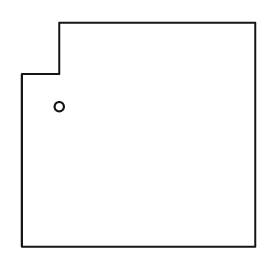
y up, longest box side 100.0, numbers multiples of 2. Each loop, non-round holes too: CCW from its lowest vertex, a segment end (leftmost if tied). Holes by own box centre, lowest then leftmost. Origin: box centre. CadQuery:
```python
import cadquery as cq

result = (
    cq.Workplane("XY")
    .moveTo(-50.0, -48.0)
    .lineTo(50.0, -48.0)
    .lineTo(50.0, 48.0)
    .lineTo(-34.0, 48.0)
    .lineTo(-34.0, 26.0)
    .lineTo(-50.0, 26.0)
    .close()
    .moveTo(-34.0, 12.0)
    .circle(2.0)
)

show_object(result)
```